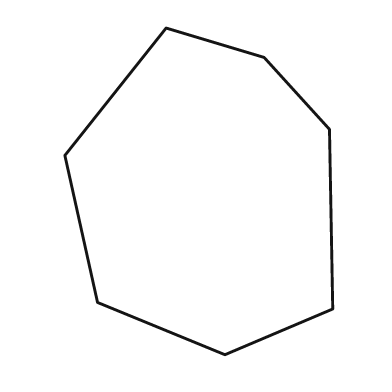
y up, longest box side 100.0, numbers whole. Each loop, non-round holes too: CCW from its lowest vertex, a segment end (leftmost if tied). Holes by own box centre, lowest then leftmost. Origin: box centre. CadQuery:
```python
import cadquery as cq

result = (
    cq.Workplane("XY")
    .moveTo(8.0, -50.0)
    .lineTo(41.0, -36.0)
    .lineTo(40.0, 19.0)
    .lineTo(20.0, 41.0)
    .lineTo(-10.0, 50.0)
    .lineTo(-41.0, 11.0)
    .lineTo(-31.0, -34.0)
    .close()
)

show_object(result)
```